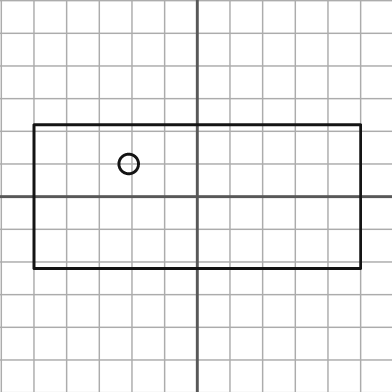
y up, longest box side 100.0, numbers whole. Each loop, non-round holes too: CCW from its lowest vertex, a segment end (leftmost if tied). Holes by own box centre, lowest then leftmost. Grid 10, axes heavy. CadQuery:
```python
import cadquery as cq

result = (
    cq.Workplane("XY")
    .moveTo(-50.0, -22.0)
    .lineTo(50.0, -22.0)
    .lineTo(50.0, 22.0)
    .lineTo(-50.0, 22.0)
    .close()
    .moveTo(-21.0, 10.0)
    .circle(3.0)
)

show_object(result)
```